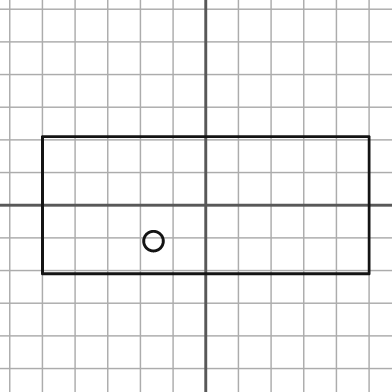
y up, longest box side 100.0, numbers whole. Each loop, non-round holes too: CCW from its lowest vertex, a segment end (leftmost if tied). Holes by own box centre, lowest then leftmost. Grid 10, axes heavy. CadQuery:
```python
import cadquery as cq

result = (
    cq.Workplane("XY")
    .moveTo(-50.0, -21.0)
    .lineTo(50.0, -21.0)
    .lineTo(50.0, 21.0)
    .lineTo(-50.0, 21.0)
    .close()
    .moveTo(-16.0, -11.0)
    .circle(3.0)
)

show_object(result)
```